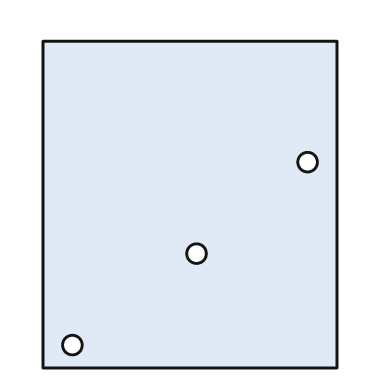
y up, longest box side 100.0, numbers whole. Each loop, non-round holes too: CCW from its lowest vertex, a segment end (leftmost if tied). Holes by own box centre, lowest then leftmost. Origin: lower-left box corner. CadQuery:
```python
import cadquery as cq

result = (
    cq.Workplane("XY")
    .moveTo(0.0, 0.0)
    .lineTo(90.0, 0.0)
    .lineTo(90.0, 100.0)
    .lineTo(0.0, 100.0)
    .close()
    .moveTo(9.0, 7.0)
    .circle(3.0)
    .moveTo(47.0, 35.0)
    .circle(3.0)
    .moveTo(81.0, 63.0)
    .circle(3.0)
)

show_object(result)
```